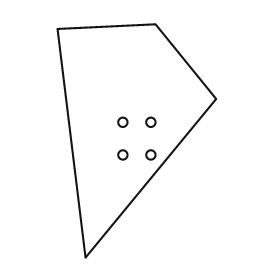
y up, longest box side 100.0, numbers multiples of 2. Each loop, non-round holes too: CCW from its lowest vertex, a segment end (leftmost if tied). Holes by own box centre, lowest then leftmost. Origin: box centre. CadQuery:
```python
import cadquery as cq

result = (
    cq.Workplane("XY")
    .moveTo(-22.0, -50.0)
    .lineTo(34.0, 18.0)
    .lineTo(8.0, 50.0)
    .lineTo(-34.0, 48.0)
    .close()
    .moveTo(-6.0, -6.0)
    .circle(2.0)
    .moveTo(6.0, -6.0)
    .circle(2.0)
    .moveTo(-6.0, 8.0)
    .circle(2.0)
    .moveTo(6.0, 8.0)
    .circle(2.0)
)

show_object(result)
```